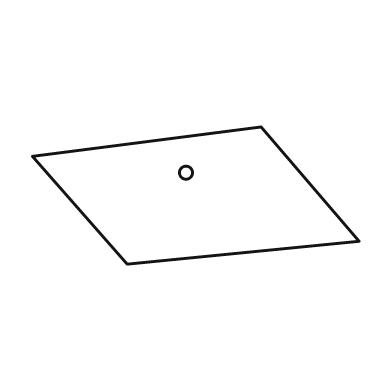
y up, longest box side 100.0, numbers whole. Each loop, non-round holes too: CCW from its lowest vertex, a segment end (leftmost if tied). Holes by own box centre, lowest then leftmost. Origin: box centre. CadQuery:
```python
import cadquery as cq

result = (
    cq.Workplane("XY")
    .moveTo(-21.0, -21.0)
    .lineTo(50.0, -14.0)
    .lineTo(20.0, 21.0)
    .lineTo(-50.0, 12.0)
    .close()
    .moveTo(-3.0, 7.0)
    .circle(2.0)
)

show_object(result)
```